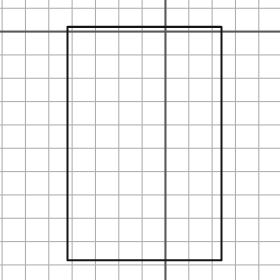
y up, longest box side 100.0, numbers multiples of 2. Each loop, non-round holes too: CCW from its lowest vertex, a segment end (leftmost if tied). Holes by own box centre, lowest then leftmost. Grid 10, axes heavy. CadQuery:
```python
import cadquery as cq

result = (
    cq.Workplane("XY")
    .moveTo(-42.0, -98.0)
    .lineTo(24.0, -98.0)
    .lineTo(24.0, 2.0)
    .lineTo(-42.0, 2.0)
    .close()
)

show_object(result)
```